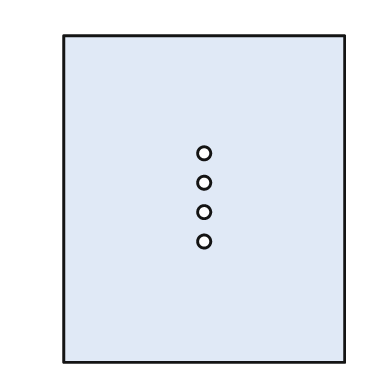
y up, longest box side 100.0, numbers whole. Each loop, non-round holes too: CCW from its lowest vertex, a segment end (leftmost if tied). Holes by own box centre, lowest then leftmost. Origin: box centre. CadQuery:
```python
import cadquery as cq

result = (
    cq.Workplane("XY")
    .moveTo(-43.0, -50.0)
    .lineTo(43.0, -50.0)
    .lineTo(43.0, 50.0)
    .lineTo(-43.0, 50.0)
    .close()
    .moveTo(0.0, -13.0)
    .circle(2.0)
    .moveTo(0.0, -4.0)
    .circle(2.0)
    .moveTo(0.0, 5.0)
    .circle(2.0)
    .moveTo(0.0, 14.0)
    .circle(2.0)
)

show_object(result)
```